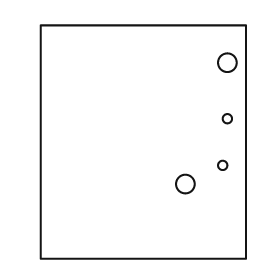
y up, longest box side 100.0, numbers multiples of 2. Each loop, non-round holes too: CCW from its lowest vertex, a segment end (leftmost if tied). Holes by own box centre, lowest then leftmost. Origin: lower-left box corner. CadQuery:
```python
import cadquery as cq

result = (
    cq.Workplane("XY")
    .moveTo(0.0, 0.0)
    .lineTo(88.0, 0.0)
    .lineTo(88.0, 100.0)
    .lineTo(0.0, 100.0)
    .close()
    .moveTo(62.0, 32.0)
    .circle(4.0)
    .moveTo(78.0, 40.0)
    .circle(2.0)
    .moveTo(80.0, 60.0)
    .circle(2.0)
    .moveTo(80.0, 84.0)
    .circle(4.0)
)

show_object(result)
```